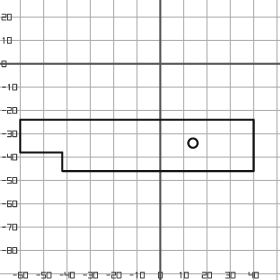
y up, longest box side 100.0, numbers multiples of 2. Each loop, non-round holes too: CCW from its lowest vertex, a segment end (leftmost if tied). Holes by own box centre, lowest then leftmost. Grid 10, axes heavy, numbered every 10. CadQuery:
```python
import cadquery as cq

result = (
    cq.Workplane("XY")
    .moveTo(-42.0, -46.0)
    .lineTo(40.0, -46.0)
    .lineTo(40.0, -24.0)
    .lineTo(-60.0, -24.0)
    .lineTo(-60.0, -38.0)
    .lineTo(-42.0, -38.0)
    .close()
    .moveTo(14.0, -34.0)
    .circle(2.0)
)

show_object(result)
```